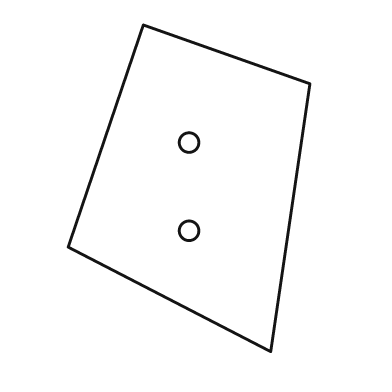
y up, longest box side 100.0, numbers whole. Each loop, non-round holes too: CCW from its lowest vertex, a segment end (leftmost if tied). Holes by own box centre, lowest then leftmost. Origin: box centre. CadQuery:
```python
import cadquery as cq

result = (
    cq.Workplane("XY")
    .moveTo(25.0, -50.0)
    .lineTo(37.0, 32.0)
    .lineTo(-14.0, 50.0)
    .lineTo(-37.0, -18.0)
    .close()
    .moveTo(0.0, -13.0)
    .circle(3.0)
    .moveTo(0.0, 14.0)
    .circle(3.0)
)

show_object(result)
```